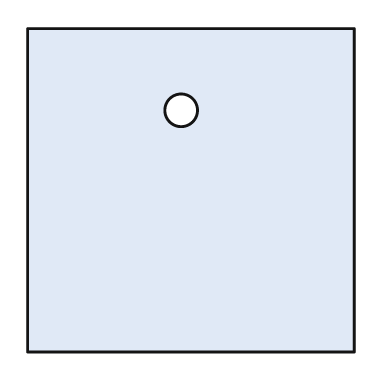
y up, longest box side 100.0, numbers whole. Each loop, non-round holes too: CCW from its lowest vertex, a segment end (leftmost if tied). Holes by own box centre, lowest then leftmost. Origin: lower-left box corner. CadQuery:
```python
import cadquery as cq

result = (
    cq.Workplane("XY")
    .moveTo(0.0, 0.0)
    .lineTo(100.0, 0.0)
    .lineTo(100.0, 99.0)
    .lineTo(0.0, 99.0)
    .close()
    .moveTo(47.0, 74.0)
    .circle(5.0)
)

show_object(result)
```